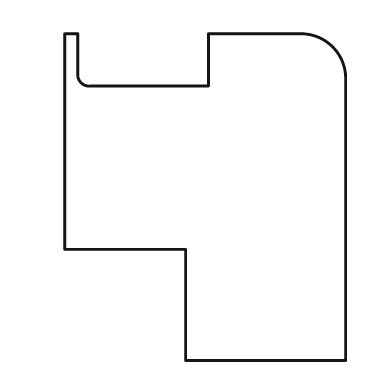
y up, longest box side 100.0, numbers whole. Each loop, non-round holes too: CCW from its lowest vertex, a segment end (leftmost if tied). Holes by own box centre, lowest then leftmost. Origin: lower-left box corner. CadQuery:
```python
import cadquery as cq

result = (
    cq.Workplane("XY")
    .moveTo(37.0, 0.0)
    .lineTo(86.0, 0.0)
    .lineTo(86.0, 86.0)
    .threePointArc((82.0, 96.0), (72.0, 100.0))
    .lineTo(44.0, 100.0)
    .lineTo(44.0, 84.0)
    .lineTo(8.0, 84.0)
    .threePointArc((5.0, 85.0), (4.0, 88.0))
    .lineTo(4.0, 100.0)
    .lineTo(0.0, 100.0)
    .lineTo(0.0, 34.0)
    .lineTo(37.0, 34.0)
    .close()
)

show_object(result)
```